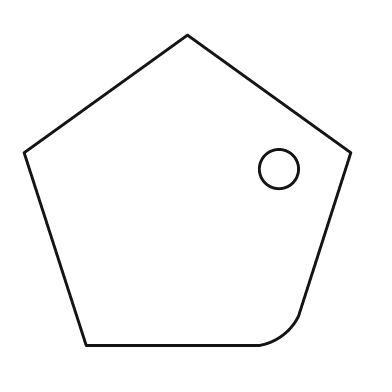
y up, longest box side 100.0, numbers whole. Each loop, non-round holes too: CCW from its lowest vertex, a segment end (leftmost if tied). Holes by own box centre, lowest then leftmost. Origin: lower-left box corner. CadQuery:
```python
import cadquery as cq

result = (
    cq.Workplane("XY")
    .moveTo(19.0, 0.0)
    .lineTo(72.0, 0.0)
    .threePointArc((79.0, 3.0), (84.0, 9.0))
    .lineTo(100.0, 59.0)
    .lineTo(50.0, 95.0)
    .lineTo(0.0, 59.0)
    .close()
    .moveTo(78.0, 54.0)
    .circle(6.0)
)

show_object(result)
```